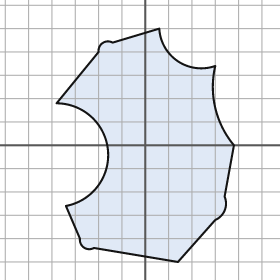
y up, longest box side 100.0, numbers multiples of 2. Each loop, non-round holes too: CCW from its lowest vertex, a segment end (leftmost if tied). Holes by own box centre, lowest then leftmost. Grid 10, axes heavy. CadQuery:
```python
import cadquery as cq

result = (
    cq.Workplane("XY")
    .moveTo(14.0, -50.0)
    .lineTo(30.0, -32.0)
    .threePointArc((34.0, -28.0), (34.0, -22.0))
    .lineTo(38.0, 0.0)
    .threePointArc((30.0, 16.0), (30.0, 34.0))
    .threePointArc((14.0, 36.0), (6.0, 50.0))
    .lineTo(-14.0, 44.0)
    .threePointArc((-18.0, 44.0), (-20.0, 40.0))
    .lineTo(-38.0, 18.0)
    .threePointArc((-16.0, -2.0), (-34.0, -26.0))
    .lineTo(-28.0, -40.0)
    .threePointArc((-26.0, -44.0), (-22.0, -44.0))
    .close()
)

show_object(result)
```